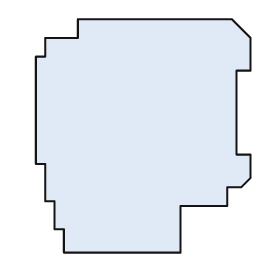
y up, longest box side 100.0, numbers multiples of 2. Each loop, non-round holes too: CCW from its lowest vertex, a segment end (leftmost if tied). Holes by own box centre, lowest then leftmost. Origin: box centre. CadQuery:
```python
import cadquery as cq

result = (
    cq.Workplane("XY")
    .moveTo(-34.0, -50.0)
    .lineTo(16.0, -50.0)
    .lineTo(16.0, -30.0)
    .lineTo(36.0, -30.0)
    .lineTo(36.0, -22.0)
    .lineTo(42.0, -22.0)
    .lineTo(46.0, -18.0)
    .lineTo(46.0, -8.0)
    .lineTo(40.0, -8.0)
    .lineTo(40.0, 28.0)
    .lineTo(46.0, 28.0)
    .lineTo(46.0, 42.0)
    .lineTo(38.0, 50.0)
    .lineTo(-28.0, 50.0)
    .lineTo(-28.0, 42.0)
    .lineTo(-42.0, 42.0)
    .lineTo(-42.0, 34.0)
    .lineTo(-46.0, 34.0)
    .lineTo(-46.0, -12.0)
    .lineTo(-42.0, -12.0)
    .lineTo(-42.0, -28.0)
    .lineTo(-38.0, -28.0)
    .lineTo(-38.0, -40.0)
    .lineTo(-34.0, -40.0)
    .close()
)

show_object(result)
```